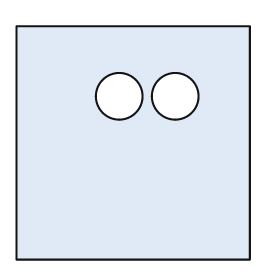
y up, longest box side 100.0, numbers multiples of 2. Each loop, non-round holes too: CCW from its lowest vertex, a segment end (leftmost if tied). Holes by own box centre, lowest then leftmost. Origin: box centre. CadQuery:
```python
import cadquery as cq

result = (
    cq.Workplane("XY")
    .moveTo(-50.0, -50.0)
    .lineTo(50.0, -50.0)
    .lineTo(50.0, 50.0)
    .lineTo(-50.0, 50.0)
    .close()
    .moveTo(-6.0, 20.0)
    .circle(10.0)
    .moveTo(18.0, 20.0)
    .circle(10.0)
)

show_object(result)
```